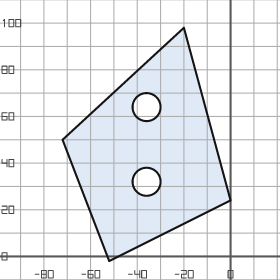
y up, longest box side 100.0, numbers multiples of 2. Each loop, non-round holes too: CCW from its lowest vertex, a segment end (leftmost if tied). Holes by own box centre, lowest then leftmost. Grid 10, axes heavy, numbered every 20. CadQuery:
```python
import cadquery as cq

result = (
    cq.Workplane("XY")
    .moveTo(-52.0, -2.0)
    .lineTo(0.0, 24.0)
    .lineTo(-20.0, 98.0)
    .lineTo(-72.0, 50.0)
    .close()
    .moveTo(-36.0, 32.0)
    .circle(6.0)
    .moveTo(-36.0, 64.0)
    .circle(6.0)
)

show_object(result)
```